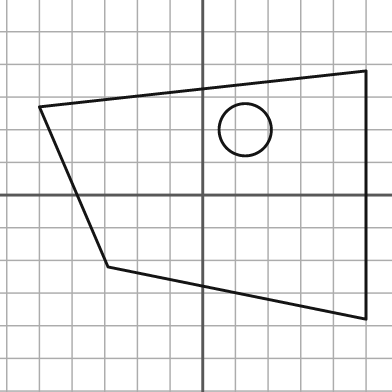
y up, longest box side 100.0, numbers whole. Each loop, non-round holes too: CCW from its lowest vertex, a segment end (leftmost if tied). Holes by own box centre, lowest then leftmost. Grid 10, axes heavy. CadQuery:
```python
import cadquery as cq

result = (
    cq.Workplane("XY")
    .moveTo(50.0, -38.0)
    .lineTo(50.0, 38.0)
    .lineTo(-50.0, 27.0)
    .lineTo(-29.0, -22.0)
    .close()
    .moveTo(13.0, 20.0)
    .circle(8.0)
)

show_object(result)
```